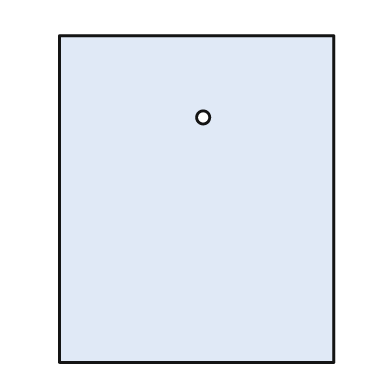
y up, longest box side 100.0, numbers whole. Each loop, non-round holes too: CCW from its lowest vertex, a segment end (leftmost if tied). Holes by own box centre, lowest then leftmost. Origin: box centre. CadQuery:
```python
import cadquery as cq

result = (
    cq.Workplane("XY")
    .moveTo(-42.0, -50.0)
    .lineTo(42.0, -50.0)
    .lineTo(42.0, 50.0)
    .lineTo(-42.0, 50.0)
    .close()
    .moveTo(2.0, 25.0)
    .circle(2.0)
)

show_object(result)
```